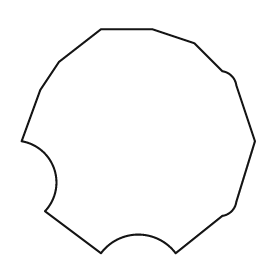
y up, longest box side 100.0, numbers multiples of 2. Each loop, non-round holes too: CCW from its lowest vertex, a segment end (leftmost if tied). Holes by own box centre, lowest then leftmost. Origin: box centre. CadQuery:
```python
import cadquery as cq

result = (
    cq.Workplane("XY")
    .moveTo(-16.0, -48.0)
    .threePointArc((0.0, -40.0), (16.0, -48.0))
    .lineTo(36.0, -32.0)
    .threePointArc((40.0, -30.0), (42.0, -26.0))
    .lineTo(50.0, 0.0)
    .lineTo(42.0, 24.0)
    .threePointArc((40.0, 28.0), (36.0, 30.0))
    .lineTo(24.0, 42.0)
    .lineTo(6.0, 48.0)
    .lineTo(-16.0, 48.0)
    .lineTo(-34.0, 34.0)
    .lineTo(-42.0, 22.0)
    .lineTo(-50.0, 0.0)
    .threePointArc((-36.0, -12.0), (-40.0, -30.0))
    .close()
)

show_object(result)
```